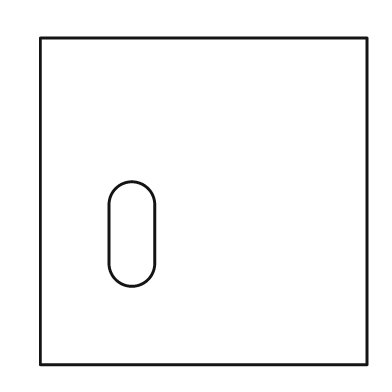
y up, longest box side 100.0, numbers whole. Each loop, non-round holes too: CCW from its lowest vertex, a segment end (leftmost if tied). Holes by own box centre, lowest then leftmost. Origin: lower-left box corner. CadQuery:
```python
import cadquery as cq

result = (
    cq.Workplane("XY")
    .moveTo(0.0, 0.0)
    .lineTo(100.0, 0.0)
    .lineTo(100.0, 100.0)
    .lineTo(0.0, 100.0)
    .close()
    .moveTo(21.0, 31.0)
    .threePointArc((28.0, 24.0), (35.0, 31.0))
    .lineTo(35.0, 49.0)
    .threePointArc((28.0, 56.0), (21.0, 49.0))
    .close()
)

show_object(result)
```